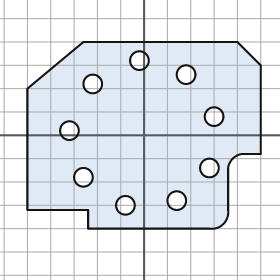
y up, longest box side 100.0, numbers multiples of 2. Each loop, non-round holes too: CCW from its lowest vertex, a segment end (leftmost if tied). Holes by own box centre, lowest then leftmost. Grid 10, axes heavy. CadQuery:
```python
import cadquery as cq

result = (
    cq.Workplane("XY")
    .moveTo(-24.0, -40.0)
    .lineTo(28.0, -40.0)
    .threePointArc((34.0, -38.0), (36.0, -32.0))
    .lineTo(36.0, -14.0)
    .threePointArc((38.0, -10.0), (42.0, -8.0))
    .lineTo(50.0, -8.0)
    .lineTo(50.0, 30.0)
    .lineTo(40.0, 40.0)
    .lineTo(-26.0, 40.0)
    .lineTo(-50.0, 20.0)
    .lineTo(-50.0, -32.0)
    .lineTo(-24.0, -32.0)
    .close()
    .moveTo(-8.0, -30.0)
    .circle(4.0)
    .moveTo(14.0, -28.0)
    .circle(4.0)
    .moveTo(-26.0, -18.0)
    .circle(4.0)
    .moveTo(28.0, -14.0)
    .circle(4.0)
    .moveTo(-32.0, 2.0)
    .circle(4.0)
    .moveTo(30.0, 8.0)
    .circle(4.0)
    .moveTo(-22.0, 22.0)
    .circle(4.0)
    .moveTo(18.0, 26.0)
    .circle(4.0)
    .moveTo(-2.0, 32.0)
    .circle(4.0)
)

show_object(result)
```